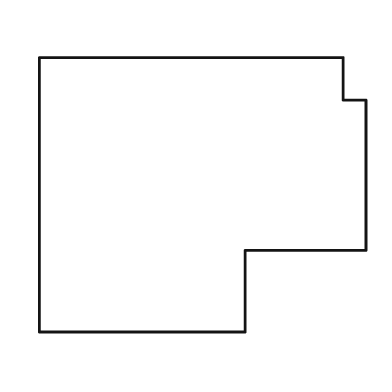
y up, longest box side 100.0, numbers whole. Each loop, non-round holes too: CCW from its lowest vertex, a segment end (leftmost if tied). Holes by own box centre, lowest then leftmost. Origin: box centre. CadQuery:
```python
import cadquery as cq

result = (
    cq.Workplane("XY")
    .moveTo(-50.0, -42.0)
    .lineTo(13.0, -42.0)
    .lineTo(13.0, -17.0)
    .lineTo(50.0, -17.0)
    .lineTo(50.0, 29.0)
    .lineTo(43.0, 29.0)
    .lineTo(43.0, 42.0)
    .lineTo(-50.0, 42.0)
    .close()
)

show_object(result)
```